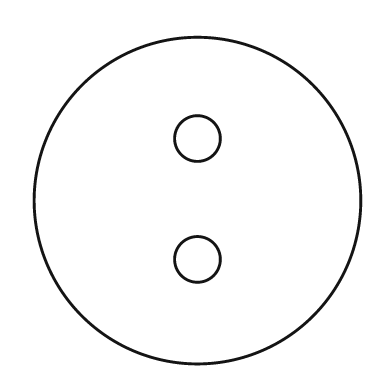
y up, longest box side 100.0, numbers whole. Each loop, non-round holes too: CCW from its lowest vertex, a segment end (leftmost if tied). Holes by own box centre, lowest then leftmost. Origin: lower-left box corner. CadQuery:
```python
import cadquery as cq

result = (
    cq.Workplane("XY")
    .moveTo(50.0, 50.0)
    .circle(50.0)
    .moveTo(50.0, 32.0)
    .circle(7.0)
    .moveTo(50.0, 69.0)
    .circle(7.0)
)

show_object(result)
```